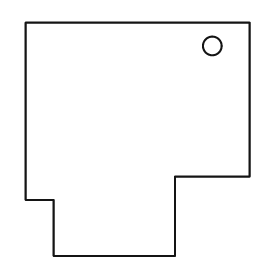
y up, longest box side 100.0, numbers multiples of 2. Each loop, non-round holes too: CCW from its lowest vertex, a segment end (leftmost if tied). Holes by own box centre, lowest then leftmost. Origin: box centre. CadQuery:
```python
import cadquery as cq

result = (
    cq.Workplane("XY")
    .moveTo(-36.0, -50.0)
    .lineTo(16.0, -50.0)
    .lineTo(16.0, -16.0)
    .lineTo(48.0, -16.0)
    .lineTo(48.0, 50.0)
    .lineTo(-48.0, 50.0)
    .lineTo(-48.0, -26.0)
    .lineTo(-36.0, -26.0)
    .close()
    .moveTo(32.0, 40.0)
    .circle(4.0)
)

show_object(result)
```